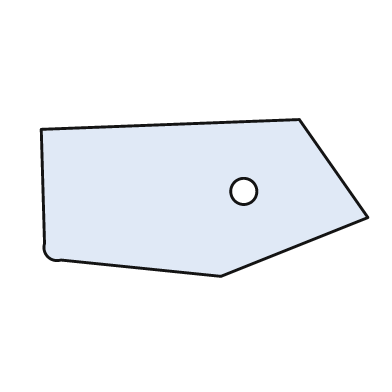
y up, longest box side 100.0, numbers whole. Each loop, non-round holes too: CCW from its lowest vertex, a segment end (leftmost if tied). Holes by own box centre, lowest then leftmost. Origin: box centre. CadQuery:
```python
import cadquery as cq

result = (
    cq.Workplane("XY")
    .moveTo(5.0, -24.0)
    .lineTo(50.0, -6.0)
    .lineTo(29.0, 24.0)
    .lineTo(-50.0, 21.0)
    .lineTo(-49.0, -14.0)
    .threePointArc((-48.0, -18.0), (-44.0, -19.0))
    .close()
    .moveTo(12.0, 2.0)
    .circle(4.0)
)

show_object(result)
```